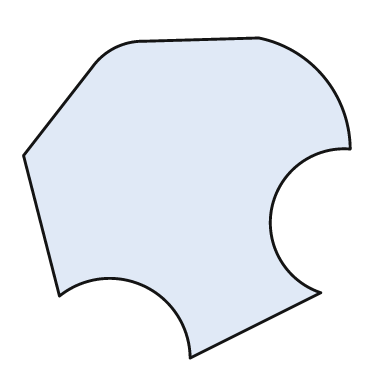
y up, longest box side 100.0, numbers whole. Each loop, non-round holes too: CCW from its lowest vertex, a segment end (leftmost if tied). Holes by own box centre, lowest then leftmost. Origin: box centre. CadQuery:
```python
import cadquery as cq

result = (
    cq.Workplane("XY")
    .moveTo(1.0, -49.0)
    .lineTo(41.0, -29.0)
    .threePointArc((26.0, -3.0), (50.0, 15.0))
    .threePointArc((42.0, 37.0), (22.0, 49.0))
    .lineTo(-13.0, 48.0)
    .threePointArc((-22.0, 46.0), (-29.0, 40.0))
    .lineTo(-50.0, 13.0)
    .lineTo(-39.0, -30.0)
    .threePointArc((-13.0, -27.0), (1.0, -49.0))
    .close()
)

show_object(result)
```